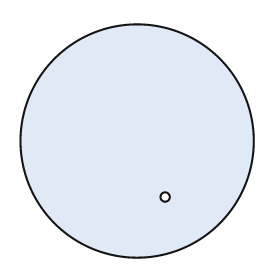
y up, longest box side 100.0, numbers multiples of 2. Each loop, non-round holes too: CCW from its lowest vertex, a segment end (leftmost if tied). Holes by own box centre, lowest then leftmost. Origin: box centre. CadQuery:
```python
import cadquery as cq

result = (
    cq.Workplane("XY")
    .moveTo(0.0, 0.0)
    .circle(50.0)
    .moveTo(12.0, -24.0)
    .circle(2.0)
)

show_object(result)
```